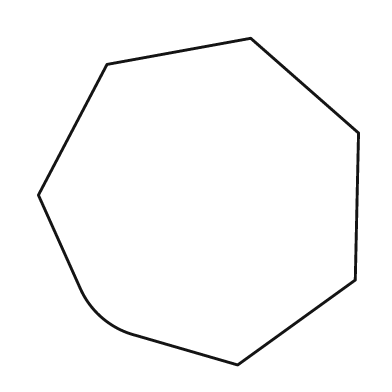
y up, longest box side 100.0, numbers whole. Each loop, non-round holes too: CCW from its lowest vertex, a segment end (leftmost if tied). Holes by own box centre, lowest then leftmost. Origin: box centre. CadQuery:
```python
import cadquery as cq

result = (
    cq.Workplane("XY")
    .moveTo(12.0, -50.0)
    .lineTo(48.0, -24.0)
    .lineTo(49.0, 21.0)
    .lineTo(16.0, 50.0)
    .lineTo(-28.0, 42.0)
    .lineTo(-49.0, 2.0)
    .lineTo(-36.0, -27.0)
    .threePointArc((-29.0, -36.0), (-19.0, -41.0))
    .close()
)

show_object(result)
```